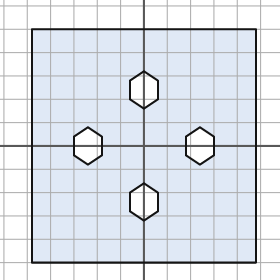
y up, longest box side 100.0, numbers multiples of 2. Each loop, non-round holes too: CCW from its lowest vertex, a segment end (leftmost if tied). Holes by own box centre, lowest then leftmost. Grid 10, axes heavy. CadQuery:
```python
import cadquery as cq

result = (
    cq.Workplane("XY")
    .moveTo(-48.0, -50.0)
    .lineTo(48.0, -50.0)
    .lineTo(48.0, 50.0)
    .lineTo(-48.0, 50.0)
    .close()
    .moveTo(0.0, -32.0)
    .lineTo(6.0, -28.0)
    .lineTo(6.0, -20.0)
    .lineTo(0.0, -16.0)
    .lineTo(-6.0, -20.0)
    .lineTo(-6.0, -28.0)
    .close()
    .moveTo(-24.0, -8.0)
    .lineTo(-18.0, -4.0)
    .lineTo(-18.0, 4.0)
    .lineTo(-24.0, 8.0)
    .lineTo(-30.0, 4.0)
    .lineTo(-30.0, -4.0)
    .close()
    .moveTo(24.0, -8.0)
    .lineTo(30.0, -4.0)
    .lineTo(30.0, 4.0)
    .lineTo(24.0, 8.0)
    .lineTo(18.0, 4.0)
    .lineTo(18.0, -4.0)
    .close()
    .moveTo(0.0, 16.0)
    .lineTo(6.0, 20.0)
    .lineTo(6.0, 28.0)
    .lineTo(0.0, 32.0)
    .lineTo(-6.0, 28.0)
    .lineTo(-6.0, 20.0)
    .close()
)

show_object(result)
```